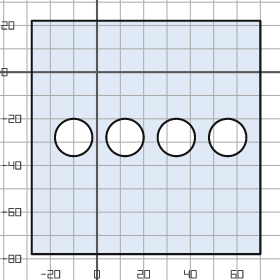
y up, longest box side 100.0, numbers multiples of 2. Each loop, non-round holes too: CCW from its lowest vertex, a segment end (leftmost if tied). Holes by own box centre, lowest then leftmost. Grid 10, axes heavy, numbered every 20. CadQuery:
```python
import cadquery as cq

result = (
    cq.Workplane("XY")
    .moveTo(-28.0, -78.0)
    .lineTo(70.0, -78.0)
    .lineTo(70.0, 22.0)
    .lineTo(-28.0, 22.0)
    .close()
    .moveTo(-10.0, -28.0)
    .circle(8.0)
    .moveTo(12.0, -28.0)
    .circle(8.0)
    .moveTo(34.0, -28.0)
    .circle(8.0)
    .moveTo(56.0, -28.0)
    .circle(8.0)
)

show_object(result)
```